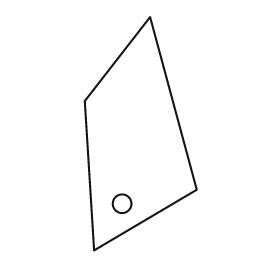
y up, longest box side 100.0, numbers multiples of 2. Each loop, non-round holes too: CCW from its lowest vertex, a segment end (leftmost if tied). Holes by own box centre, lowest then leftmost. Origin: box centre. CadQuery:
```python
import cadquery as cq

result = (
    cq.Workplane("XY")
    .moveTo(-20.0, -50.0)
    .lineTo(24.0, -24.0)
    .lineTo(4.0, 50.0)
    .lineTo(-24.0, 14.0)
    .close()
    .moveTo(-8.0, -30.0)
    .circle(4.0)
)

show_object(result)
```